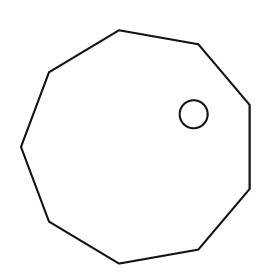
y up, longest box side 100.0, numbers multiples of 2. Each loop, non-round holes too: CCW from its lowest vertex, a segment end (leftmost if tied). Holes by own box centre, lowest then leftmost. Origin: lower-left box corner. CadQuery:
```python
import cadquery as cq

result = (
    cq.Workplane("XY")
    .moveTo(42.0, 0.0)
    .lineTo(76.0, 6.0)
    .lineTo(98.0, 32.0)
    .lineTo(98.0, 68.0)
    .lineTo(76.0, 94.0)
    .lineTo(42.0, 100.0)
    .lineTo(12.0, 82.0)
    .lineTo(0.0, 50.0)
    .lineTo(12.0, 18.0)
    .close()
    .moveTo(74.0, 64.0)
    .circle(6.0)
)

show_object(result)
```